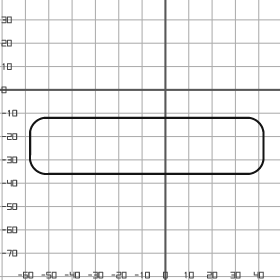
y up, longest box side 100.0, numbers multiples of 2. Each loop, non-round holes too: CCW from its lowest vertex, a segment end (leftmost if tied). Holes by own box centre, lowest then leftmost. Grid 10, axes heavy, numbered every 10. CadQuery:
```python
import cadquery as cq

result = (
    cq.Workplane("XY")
    .moveTo(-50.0, -36.0)
    .lineTo(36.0, -36.0)
    .threePointArc((40.0, -34.0), (42.0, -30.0))
    .lineTo(42.0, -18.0)
    .threePointArc((40.0, -14.0), (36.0, -12.0))
    .lineTo(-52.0, -12.0)
    .threePointArc((-56.0, -14.0), (-58.0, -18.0))
    .lineTo(-58.0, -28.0)
    .threePointArc((-56.0, -34.0), (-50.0, -36.0))
    .close()
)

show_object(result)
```